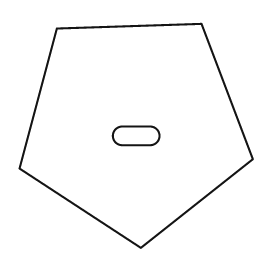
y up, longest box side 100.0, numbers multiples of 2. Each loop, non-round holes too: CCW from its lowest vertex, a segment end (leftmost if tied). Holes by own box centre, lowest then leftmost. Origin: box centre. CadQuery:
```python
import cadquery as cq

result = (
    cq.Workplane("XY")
    .moveTo(2.0, -48.0)
    .lineTo(50.0, -10.0)
    .lineTo(28.0, 48.0)
    .lineTo(-34.0, 46.0)
    .lineTo(-50.0, -14.0)
    .close()
    .moveTo(-6.0, -4.0)
    .lineTo(6.0, -4.0)
    .threePointArc((10.0, 0.0), (6.0, 4.0))
    .lineTo(-6.0, 4.0)
    .threePointArc((-10.0, 0.0), (-6.0, -4.0))
    .close()
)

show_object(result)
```